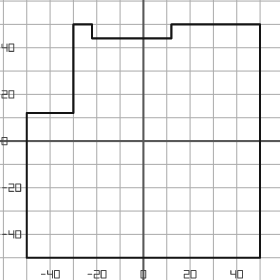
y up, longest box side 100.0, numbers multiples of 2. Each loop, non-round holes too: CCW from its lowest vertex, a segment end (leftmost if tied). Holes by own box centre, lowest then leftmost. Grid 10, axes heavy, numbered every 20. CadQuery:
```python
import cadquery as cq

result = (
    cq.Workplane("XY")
    .moveTo(-50.0, -50.0)
    .lineTo(50.0, -50.0)
    .lineTo(50.0, 50.0)
    .lineTo(12.0, 50.0)
    .lineTo(12.0, 44.0)
    .lineTo(-22.0, 44.0)
    .lineTo(-22.0, 50.0)
    .lineTo(-30.0, 50.0)
    .lineTo(-30.0, 12.0)
    .lineTo(-50.0, 12.0)
    .close()
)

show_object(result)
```